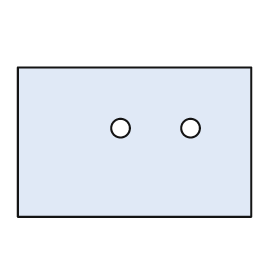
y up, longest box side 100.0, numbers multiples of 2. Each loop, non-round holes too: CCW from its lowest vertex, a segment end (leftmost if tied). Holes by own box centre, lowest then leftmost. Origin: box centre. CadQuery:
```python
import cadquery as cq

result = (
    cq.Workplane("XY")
    .moveTo(-50.0, -32.0)
    .lineTo(50.0, -32.0)
    .lineTo(50.0, 32.0)
    .lineTo(-50.0, 32.0)
    .close()
    .moveTo(-6.0, 6.0)
    .circle(4.0)
    .moveTo(24.0, 6.0)
    .circle(4.0)
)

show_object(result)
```